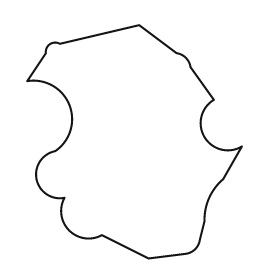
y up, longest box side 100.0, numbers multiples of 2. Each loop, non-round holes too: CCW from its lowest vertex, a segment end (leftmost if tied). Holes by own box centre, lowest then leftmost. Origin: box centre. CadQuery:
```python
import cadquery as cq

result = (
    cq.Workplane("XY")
    .moveTo(6.0, -50.0)
    .lineTo(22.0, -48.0)
    .threePointArc((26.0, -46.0), (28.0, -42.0))
    .lineTo(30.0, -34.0)
    .threePointArc((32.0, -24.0), (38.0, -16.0))
    .lineTo(46.0, -2.0)
    .threePointArc((30.0, 2.0), (34.0, 18.0))
    .lineTo(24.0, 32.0)
    .threePointArc((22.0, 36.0), (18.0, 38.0))
    .lineTo(2.0, 50.0)
    .lineTo(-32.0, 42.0)
    .threePointArc((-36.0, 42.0), (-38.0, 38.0))
    .lineTo(-46.0, 26.0)
    .threePointArc((-28.0, 16.0), (-34.0, -4.0))
    .threePointArc((-42.0, -16.0), (-30.0, -24.0))
    .threePointArc((-28.0, -38.0), (-14.0, -40.0))
    .close()
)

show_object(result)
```